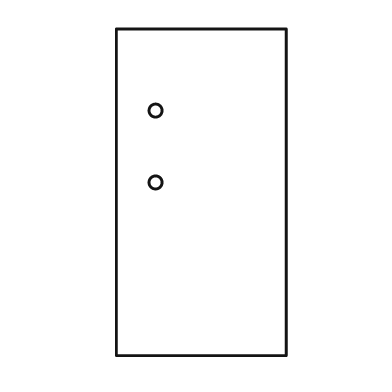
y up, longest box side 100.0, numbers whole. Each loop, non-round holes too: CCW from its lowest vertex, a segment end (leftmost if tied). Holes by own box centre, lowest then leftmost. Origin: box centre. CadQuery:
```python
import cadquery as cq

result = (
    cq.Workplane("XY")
    .moveTo(-26.0, -50.0)
    .lineTo(26.0, -50.0)
    .lineTo(26.0, 50.0)
    .lineTo(-26.0, 50.0)
    .close()
    .moveTo(-14.0, 3.0)
    .circle(2.0)
    .moveTo(-14.0, 25.0)
    .circle(2.0)
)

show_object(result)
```